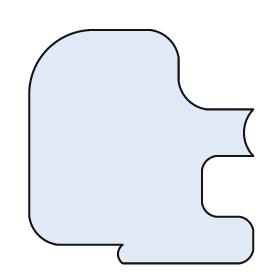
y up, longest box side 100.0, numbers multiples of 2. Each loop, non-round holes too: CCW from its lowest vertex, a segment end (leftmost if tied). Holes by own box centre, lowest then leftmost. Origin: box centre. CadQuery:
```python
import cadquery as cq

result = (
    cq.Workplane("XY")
    .moveTo(-8.0, -50.0)
    .lineTo(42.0, -50.0)
    .threePointArc((46.0, -48.0), (48.0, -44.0))
    .lineTo(48.0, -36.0)
    .threePointArc((46.0, -32.0), (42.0, -30.0))
    .lineTo(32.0, -30.0)
    .threePointArc((28.0, -28.0), (26.0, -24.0))
    .lineTo(26.0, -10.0)
    .threePointArc((28.0, -6.0), (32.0, -4.0))
    .lineTo(48.0, -4.0)
    .threePointArc((44.0, 6.0), (48.0, 16.0))
    .lineTo(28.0, 16.0)
    .threePointArc((20.0, 20.0), (16.0, 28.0))
    .lineTo(16.0, 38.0)
    .threePointArc((12.0, 46.0), (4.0, 50.0))
    .lineTo(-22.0, 50.0)
    .threePointArc((-40.0, 42.0), (-48.0, 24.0))
    .lineTo(-48.0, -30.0)
    .threePointArc((-44.0, -38.0), (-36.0, -42.0))
    .lineTo(-8.0, -42.0)
    .threePointArc((-10.0, -46.0), (-8.0, -50.0))
    .close()
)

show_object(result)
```